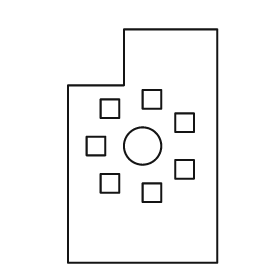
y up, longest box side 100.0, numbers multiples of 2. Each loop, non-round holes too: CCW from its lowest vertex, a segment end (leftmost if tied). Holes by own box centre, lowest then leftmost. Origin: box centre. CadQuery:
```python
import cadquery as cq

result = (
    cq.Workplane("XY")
    .moveTo(-32.0, -50.0)
    .lineTo(32.0, -50.0)
    .lineTo(32.0, 50.0)
    .lineTo(-8.0, 50.0)
    .lineTo(-8.0, 26.0)
    .lineTo(-32.0, 26.0)
    .close()
    .moveTo(0.0, -24.0)
    .lineTo(8.0, -24.0)
    .lineTo(8.0, -16.0)
    .lineTo(0.0, -16.0)
    .close()
    .moveTo(-18.0, -20.0)
    .lineTo(-10.0, -20.0)
    .lineTo(-10.0, -12.0)
    .lineTo(-18.0, -12.0)
    .close()
    .moveTo(14.0, -14.0)
    .lineTo(22.0, -14.0)
    .lineTo(22.0, -6.0)
    .lineTo(14.0, -6.0)
    .close()
    .moveTo(-24.0, -4.0)
    .lineTo(-16.0, -4.0)
    .lineTo(-16.0, 4.0)
    .lineTo(-24.0, 4.0)
    .close()
    .moveTo(0.0, 0.0)
    .circle(8.0)
    .moveTo(14.0, 6.0)
    .lineTo(22.0, 6.0)
    .lineTo(22.0, 14.0)
    .lineTo(14.0, 14.0)
    .close()
    .moveTo(-18.0, 12.0)
    .lineTo(-10.0, 12.0)
    .lineTo(-10.0, 20.0)
    .lineTo(-18.0, 20.0)
    .close()
    .moveTo(0.0, 16.0)
    .lineTo(8.0, 16.0)
    .lineTo(8.0, 24.0)
    .lineTo(0.0, 24.0)
    .close()
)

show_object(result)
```